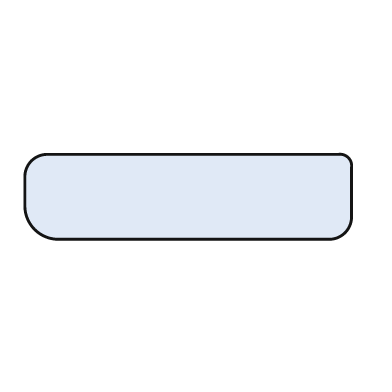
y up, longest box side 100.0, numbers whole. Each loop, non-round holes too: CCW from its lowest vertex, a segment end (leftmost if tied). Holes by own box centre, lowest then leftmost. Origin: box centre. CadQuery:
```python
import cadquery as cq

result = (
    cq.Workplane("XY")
    .moveTo(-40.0, -13.0)
    .lineTo(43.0, -13.0)
    .threePointArc((48.0, -11.0), (50.0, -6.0))
    .lineTo(50.0, 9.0)
    .threePointArc((49.0, 12.0), (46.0, 13.0))
    .lineTo(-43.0, 13.0)
    .threePointArc((-48.0, 11.0), (-50.0, 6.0))
    .lineTo(-50.0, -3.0)
    .threePointArc((-47.0, -10.0), (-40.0, -13.0))
    .close()
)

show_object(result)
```